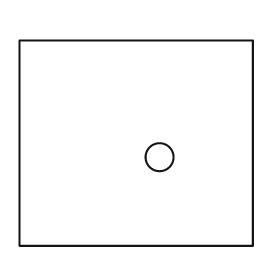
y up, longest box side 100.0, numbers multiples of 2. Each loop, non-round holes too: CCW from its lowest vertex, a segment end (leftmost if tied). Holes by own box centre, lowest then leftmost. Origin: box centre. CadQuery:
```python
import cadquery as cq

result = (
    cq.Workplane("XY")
    .moveTo(-50.0, -44.0)
    .lineTo(50.0, -44.0)
    .lineTo(50.0, 44.0)
    .lineTo(-50.0, 44.0)
    .close()
    .moveTo(10.0, -6.0)
    .circle(6.0)
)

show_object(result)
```